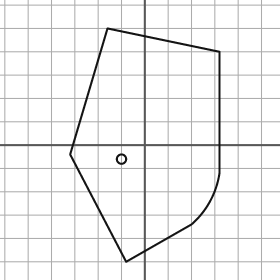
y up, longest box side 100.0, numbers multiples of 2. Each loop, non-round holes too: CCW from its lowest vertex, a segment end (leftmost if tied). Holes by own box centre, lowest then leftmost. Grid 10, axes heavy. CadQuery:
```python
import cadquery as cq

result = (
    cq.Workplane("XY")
    .moveTo(-8.0, -50.0)
    .lineTo(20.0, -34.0)
    .threePointArc((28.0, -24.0), (32.0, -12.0))
    .lineTo(32.0, 40.0)
    .lineTo(-16.0, 50.0)
    .lineTo(-32.0, -4.0)
    .close()
    .moveTo(-10.0, -6.0)
    .circle(2.0)
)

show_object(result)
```